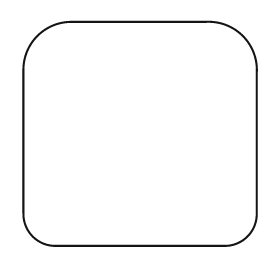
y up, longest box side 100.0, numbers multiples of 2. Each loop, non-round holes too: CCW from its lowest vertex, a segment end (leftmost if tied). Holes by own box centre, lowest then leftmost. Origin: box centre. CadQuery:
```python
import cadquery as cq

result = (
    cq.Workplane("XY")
    .moveTo(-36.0, -48.0)
    .lineTo(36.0, -48.0)
    .threePointArc((46.0, -44.0), (50.0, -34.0))
    .lineTo(50.0, 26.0)
    .threePointArc((44.0, 42.0), (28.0, 48.0))
    .lineTo(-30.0, 48.0)
    .threePointArc((-44.0, 42.0), (-50.0, 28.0))
    .lineTo(-50.0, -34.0)
    .threePointArc((-46.0, -44.0), (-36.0, -48.0))
    .close()
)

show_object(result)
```